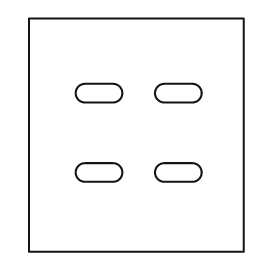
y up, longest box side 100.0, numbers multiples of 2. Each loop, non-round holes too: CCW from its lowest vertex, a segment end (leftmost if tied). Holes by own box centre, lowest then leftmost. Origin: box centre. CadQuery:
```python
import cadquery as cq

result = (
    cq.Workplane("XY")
    .moveTo(-46.0, -50.0)
    .lineTo(46.0, -50.0)
    .lineTo(46.0, 50.0)
    .lineTo(-46.0, 50.0)
    .close()
    .moveTo(-22.0, -20.0)
    .lineTo(-10.0, -20.0)
    .threePointArc((-6.0, -16.0), (-10.0, -12.0))
    .lineTo(-22.0, -12.0)
    .threePointArc((-26.0, -16.0), (-22.0, -20.0))
    .close()
    .moveTo(12.0, -20.0)
    .lineTo(24.0, -20.0)
    .threePointArc((28.0, -16.0), (24.0, -12.0))
    .lineTo(12.0, -12.0)
    .threePointArc((8.0, -16.0), (12.0, -20.0))
    .close()
    .moveTo(-22.0, 14.0)
    .lineTo(-10.0, 14.0)
    .threePointArc((-6.0, 18.0), (-10.0, 22.0))
    .lineTo(-22.0, 22.0)
    .threePointArc((-26.0, 18.0), (-22.0, 14.0))
    .close()
    .moveTo(12.0, 14.0)
    .lineTo(24.0, 14.0)
    .threePointArc((28.0, 18.0), (24.0, 22.0))
    .lineTo(12.0, 22.0)
    .threePointArc((8.0, 18.0), (12.0, 14.0))
    .close()
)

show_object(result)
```